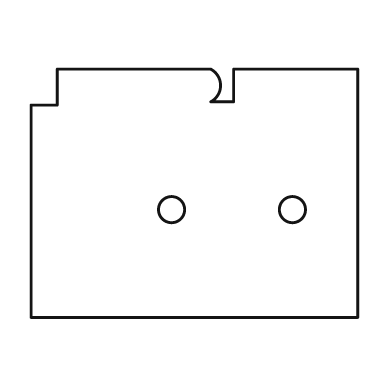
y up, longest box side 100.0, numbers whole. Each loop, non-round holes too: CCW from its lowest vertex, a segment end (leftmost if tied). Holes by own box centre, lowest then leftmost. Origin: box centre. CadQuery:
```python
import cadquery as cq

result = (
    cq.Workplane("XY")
    .moveTo(-50.0, -38.0)
    .lineTo(50.0, -38.0)
    .lineTo(50.0, 38.0)
    .lineTo(12.0, 38.0)
    .lineTo(12.0, 28.0)
    .lineTo(5.0, 28.0)
    .threePointArc((8.0, 33.0), (5.0, 38.0))
    .lineTo(-42.0, 38.0)
    .lineTo(-42.0, 27.0)
    .lineTo(-50.0, 27.0)
    .close()
    .moveTo(-7.0, -5.0)
    .circle(4.0)
    .moveTo(30.0, -5.0)
    .circle(4.0)
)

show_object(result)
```